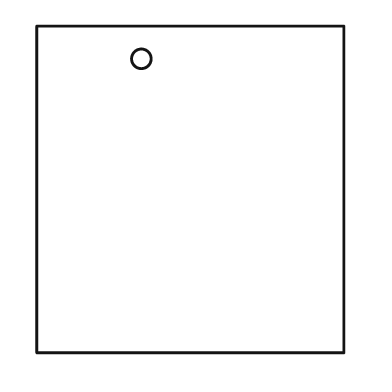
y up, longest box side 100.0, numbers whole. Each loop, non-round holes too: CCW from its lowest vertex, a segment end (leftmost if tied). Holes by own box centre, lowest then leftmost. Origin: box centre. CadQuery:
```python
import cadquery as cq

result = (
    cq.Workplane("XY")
    .moveTo(-47.0, -50.0)
    .lineTo(47.0, -50.0)
    .lineTo(47.0, 50.0)
    .lineTo(-47.0, 50.0)
    .close()
    .moveTo(-15.0, 40.0)
    .circle(3.0)
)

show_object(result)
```